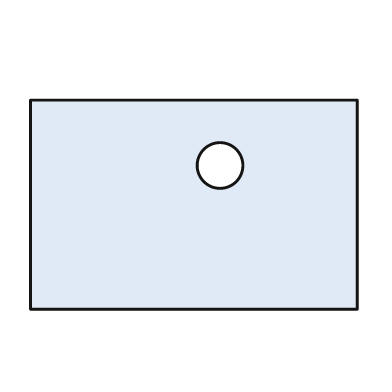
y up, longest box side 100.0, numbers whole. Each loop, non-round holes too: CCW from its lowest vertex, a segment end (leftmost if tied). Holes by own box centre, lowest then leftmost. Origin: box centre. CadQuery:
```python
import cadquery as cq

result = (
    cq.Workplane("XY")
    .moveTo(-50.0, -32.0)
    .lineTo(50.0, -32.0)
    .lineTo(50.0, 32.0)
    .lineTo(-50.0, 32.0)
    .close()
    .moveTo(8.0, 12.0)
    .circle(7.0)
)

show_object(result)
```